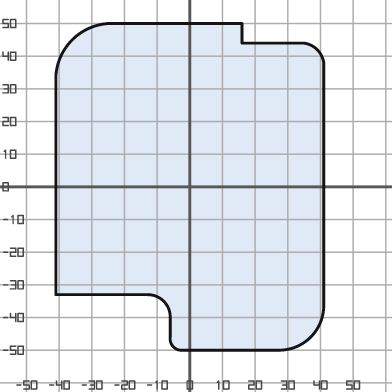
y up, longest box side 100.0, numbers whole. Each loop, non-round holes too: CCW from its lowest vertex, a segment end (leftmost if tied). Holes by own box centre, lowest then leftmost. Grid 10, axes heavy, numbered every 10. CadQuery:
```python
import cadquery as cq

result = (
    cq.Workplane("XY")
    .moveTo(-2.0, -50.0)
    .lineTo(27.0, -50.0)
    .threePointArc((37.0, -46.0), (41.0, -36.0))
    .lineTo(41.0, 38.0)
    .threePointArc((39.0, 42.0), (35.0, 44.0))
    .lineTo(16.0, 44.0)
    .lineTo(16.0, 50.0)
    .lineTo(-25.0, 50.0)
    .threePointArc((-36.0, 45.0), (-41.0, 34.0))
    .lineTo(-41.0, -33.0)
    .lineTo(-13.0, -33.0)
    .threePointArc((-8.0, -35.0), (-6.0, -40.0))
    .lineTo(-6.0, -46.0)
    .threePointArc((-5.0, -49.0), (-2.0, -50.0))
    .close()
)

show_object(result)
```